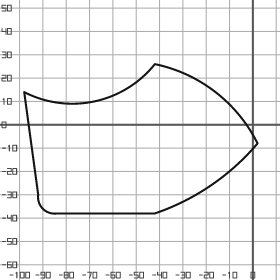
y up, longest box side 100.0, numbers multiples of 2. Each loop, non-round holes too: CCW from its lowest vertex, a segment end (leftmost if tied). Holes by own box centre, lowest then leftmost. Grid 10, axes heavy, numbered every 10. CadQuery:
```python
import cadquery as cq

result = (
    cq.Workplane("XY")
    .moveTo(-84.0, -38.0)
    .lineTo(-42.0, -38.0)
    .threePointArc((-18.0, -26.0), (2.0, -8.0))
    .threePointArc((-16.0, 14.0), (-42.0, 26.0))
    .threePointArc((-68.0, 10.0), (-98.0, 14.0))
    .lineTo(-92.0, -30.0)
    .threePointArc((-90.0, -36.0), (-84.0, -38.0))
    .close()
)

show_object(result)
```